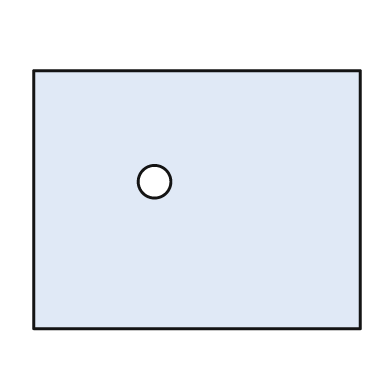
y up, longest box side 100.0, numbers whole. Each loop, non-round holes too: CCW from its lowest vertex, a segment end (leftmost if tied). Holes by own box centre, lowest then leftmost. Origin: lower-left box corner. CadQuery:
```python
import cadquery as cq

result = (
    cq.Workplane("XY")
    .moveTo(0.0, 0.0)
    .lineTo(100.0, 0.0)
    .lineTo(100.0, 79.0)
    .lineTo(0.0, 79.0)
    .close()
    .moveTo(37.0, 45.0)
    .circle(5.0)
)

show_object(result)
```